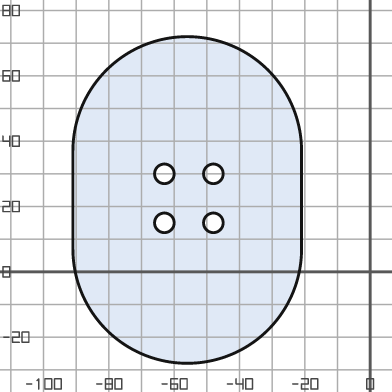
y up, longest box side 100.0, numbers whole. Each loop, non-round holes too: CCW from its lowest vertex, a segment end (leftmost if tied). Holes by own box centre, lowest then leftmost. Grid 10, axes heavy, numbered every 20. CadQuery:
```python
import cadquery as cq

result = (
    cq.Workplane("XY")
    .moveTo(-91.0, 7.0)
    .threePointArc((-56.0, -28.0), (-21.0, 7.0))
    .lineTo(-21.0, 37.0)
    .threePointArc((-56.0, 72.0), (-91.0, 37.0))
    .close()
    .moveTo(-63.0, 15.0)
    .circle(3.0)
    .moveTo(-48.0, 15.0)
    .circle(3.0)
    .moveTo(-63.0, 30.0)
    .circle(3.0)
    .moveTo(-48.0, 30.0)
    .circle(3.0)
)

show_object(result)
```